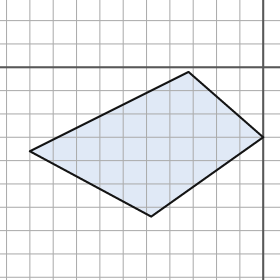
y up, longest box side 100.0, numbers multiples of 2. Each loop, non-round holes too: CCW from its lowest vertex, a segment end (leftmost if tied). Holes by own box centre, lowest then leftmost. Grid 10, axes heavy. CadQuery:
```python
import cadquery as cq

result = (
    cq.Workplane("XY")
    .moveTo(-48.0, -64.0)
    .lineTo(0.0, -30.0)
    .lineTo(-32.0, -2.0)
    .lineTo(-100.0, -36.0)
    .close()
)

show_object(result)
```